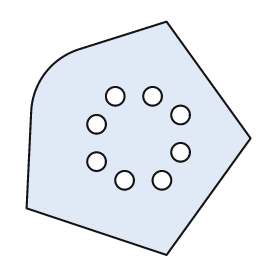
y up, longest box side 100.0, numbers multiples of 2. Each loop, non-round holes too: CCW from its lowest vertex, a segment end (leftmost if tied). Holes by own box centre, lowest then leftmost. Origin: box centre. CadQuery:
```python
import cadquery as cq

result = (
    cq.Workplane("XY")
    .moveTo(12.0, -50.0)
    .lineTo(48.0, 0.0)
    .lineTo(12.0, 50.0)
    .lineTo(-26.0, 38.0)
    .threePointArc((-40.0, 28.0), (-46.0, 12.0))
    .lineTo(-48.0, -30.0)
    .close()
    .moveTo(-6.0, -18.0)
    .circle(4.0)
    .moveTo(10.0, -18.0)
    .circle(4.0)
    .moveTo(-18.0, -10.0)
    .circle(4.0)
    .moveTo(18.0, -6.0)
    .circle(4.0)
    .moveTo(-18.0, 6.0)
    .circle(4.0)
    .moveTo(18.0, 10.0)
    .circle(4.0)
    .moveTo(-10.0, 18.0)
    .circle(4.0)
    .moveTo(6.0, 18.0)
    .circle(4.0)
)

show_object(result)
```